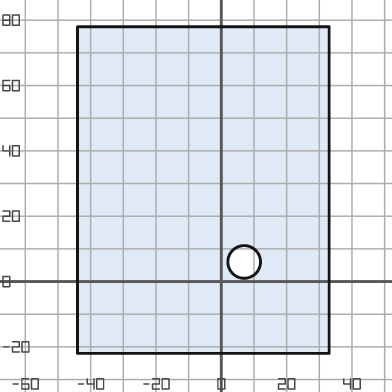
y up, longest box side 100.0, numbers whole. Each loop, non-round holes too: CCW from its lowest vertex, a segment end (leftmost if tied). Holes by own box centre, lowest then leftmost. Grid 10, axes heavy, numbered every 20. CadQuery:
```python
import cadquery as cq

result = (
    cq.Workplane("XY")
    .moveTo(-44.0, -22.0)
    .lineTo(33.0, -22.0)
    .lineTo(33.0, 78.0)
    .lineTo(-44.0, 78.0)
    .close()
    .moveTo(7.0, 6.0)
    .circle(5.0)
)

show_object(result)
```